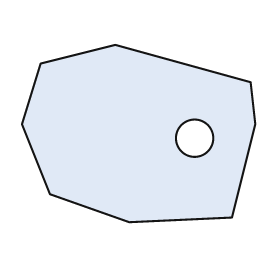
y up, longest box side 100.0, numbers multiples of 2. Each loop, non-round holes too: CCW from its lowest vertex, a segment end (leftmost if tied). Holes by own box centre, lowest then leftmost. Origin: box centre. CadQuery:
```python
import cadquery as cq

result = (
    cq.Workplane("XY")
    .moveTo(-4.0, -38.0)
    .lineTo(40.0, -36.0)
    .lineTo(50.0, 4.0)
    .lineTo(48.0, 22.0)
    .lineTo(-10.0, 38.0)
    .lineTo(-42.0, 30.0)
    .lineTo(-50.0, 4.0)
    .lineTo(-38.0, -26.0)
    .close()
    .moveTo(24.0, -2.0)
    .circle(8.0)
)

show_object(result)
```